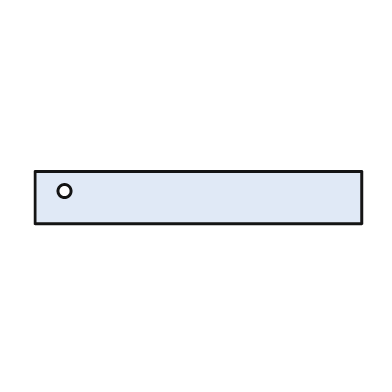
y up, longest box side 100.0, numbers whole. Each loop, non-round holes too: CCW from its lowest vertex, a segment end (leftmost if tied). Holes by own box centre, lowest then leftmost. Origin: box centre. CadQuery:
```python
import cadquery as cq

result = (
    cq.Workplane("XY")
    .moveTo(-50.0, -8.0)
    .lineTo(50.0, -8.0)
    .lineTo(50.0, 8.0)
    .lineTo(-50.0, 8.0)
    .close()
    .moveTo(-41.0, 2.0)
    .circle(2.0)
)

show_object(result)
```